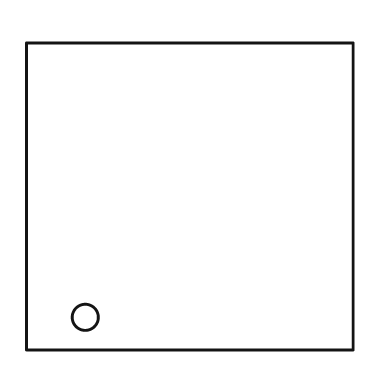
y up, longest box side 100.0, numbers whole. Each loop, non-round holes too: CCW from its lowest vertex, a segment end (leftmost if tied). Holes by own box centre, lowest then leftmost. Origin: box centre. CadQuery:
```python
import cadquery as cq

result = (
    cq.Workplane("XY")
    .moveTo(-50.0, -47.0)
    .lineTo(50.0, -47.0)
    .lineTo(50.0, 47.0)
    .lineTo(-50.0, 47.0)
    .close()
    .moveTo(-32.0, -37.0)
    .circle(4.0)
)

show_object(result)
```